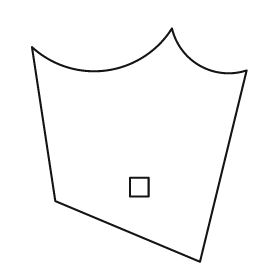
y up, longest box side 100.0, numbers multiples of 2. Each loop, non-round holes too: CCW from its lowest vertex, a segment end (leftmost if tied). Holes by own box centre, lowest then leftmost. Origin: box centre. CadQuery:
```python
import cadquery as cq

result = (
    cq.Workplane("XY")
    .moveTo(26.0, -50.0)
    .lineTo(46.0, 32.0)
    .threePointArc((26.0, 34.0), (14.0, 50.0))
    .threePointArc((-14.0, 32.0), (-46.0, 42.0))
    .lineTo(-36.0, -24.0)
    .close()
    .moveTo(-4.0, -22.0)
    .lineTo(4.0, -22.0)
    .lineTo(4.0, -14.0)
    .lineTo(-4.0, -14.0)
    .close()
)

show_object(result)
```